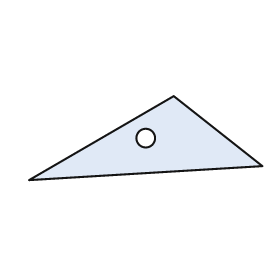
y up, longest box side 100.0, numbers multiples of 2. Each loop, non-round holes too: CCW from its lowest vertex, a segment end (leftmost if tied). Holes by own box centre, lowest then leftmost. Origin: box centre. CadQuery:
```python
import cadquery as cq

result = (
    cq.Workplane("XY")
    .moveTo(-50.0, -18.0)
    .lineTo(50.0, -12.0)
    .lineTo(12.0, 18.0)
    .close()
    .moveTo(0.0, 0.0)
    .circle(4.0)
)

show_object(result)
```